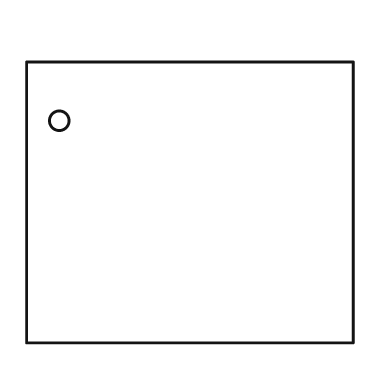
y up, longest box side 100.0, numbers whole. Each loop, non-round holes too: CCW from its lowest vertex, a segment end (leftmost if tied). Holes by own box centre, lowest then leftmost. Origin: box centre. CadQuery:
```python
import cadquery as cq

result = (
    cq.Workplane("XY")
    .moveTo(-50.0, -43.0)
    .lineTo(50.0, -43.0)
    .lineTo(50.0, 43.0)
    .lineTo(-50.0, 43.0)
    .close()
    .moveTo(-40.0, 25.0)
    .circle(3.0)
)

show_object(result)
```